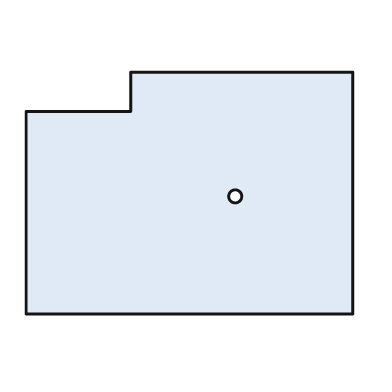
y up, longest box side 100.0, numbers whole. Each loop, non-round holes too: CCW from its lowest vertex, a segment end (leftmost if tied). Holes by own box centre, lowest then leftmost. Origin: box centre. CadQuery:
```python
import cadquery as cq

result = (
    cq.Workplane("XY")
    .moveTo(-50.0, -37.0)
    .lineTo(50.0, -37.0)
    .lineTo(50.0, 37.0)
    .lineTo(-18.0, 37.0)
    .lineTo(-18.0, 25.0)
    .lineTo(-50.0, 25.0)
    .close()
    .moveTo(14.0, -1.0)
    .circle(2.0)
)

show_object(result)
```